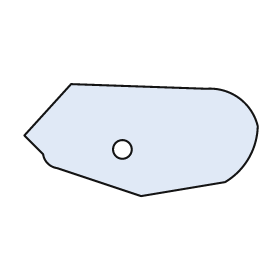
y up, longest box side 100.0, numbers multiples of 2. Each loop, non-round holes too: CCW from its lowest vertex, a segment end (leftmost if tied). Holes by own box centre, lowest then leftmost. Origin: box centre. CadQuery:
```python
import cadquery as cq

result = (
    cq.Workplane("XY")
    .moveTo(0.0, -24.0)
    .lineTo(36.0, -18.0)
    .threePointArc((46.0, -8.0), (50.0, 6.0))
    .threePointArc((42.0, 18.0), (28.0, 22.0))
    .lineTo(-30.0, 24.0)
    .lineTo(-50.0, 2.0)
    .lineTo(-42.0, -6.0)
    .threePointArc((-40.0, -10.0), (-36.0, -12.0))
    .close()
    .moveTo(-8.0, -4.0)
    .circle(4.0)
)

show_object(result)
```